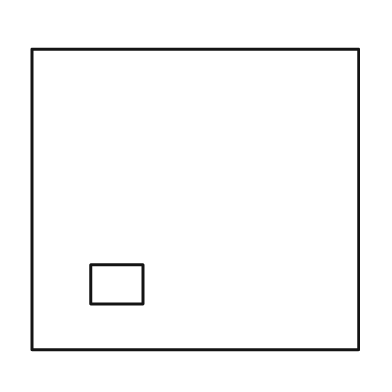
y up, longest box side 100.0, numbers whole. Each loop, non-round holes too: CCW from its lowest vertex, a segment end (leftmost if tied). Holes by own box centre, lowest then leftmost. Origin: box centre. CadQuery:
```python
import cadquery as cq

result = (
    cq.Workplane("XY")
    .moveTo(-50.0, -46.0)
    .lineTo(50.0, -46.0)
    .lineTo(50.0, 46.0)
    .lineTo(-50.0, 46.0)
    .close()
    .moveTo(-32.0, -32.0)
    .lineTo(-16.0, -32.0)
    .lineTo(-16.0, -20.0)
    .lineTo(-32.0, -20.0)
    .close()
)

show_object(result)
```